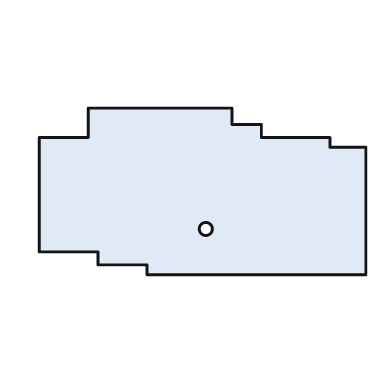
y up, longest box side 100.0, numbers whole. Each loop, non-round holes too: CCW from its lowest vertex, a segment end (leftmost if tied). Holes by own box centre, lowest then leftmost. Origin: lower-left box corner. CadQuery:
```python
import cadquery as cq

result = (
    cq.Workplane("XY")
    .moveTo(33.0, 0.0)
    .lineTo(100.0, 0.0)
    .lineTo(100.0, 39.0)
    .lineTo(89.0, 39.0)
    .lineTo(89.0, 42.0)
    .lineTo(68.0, 42.0)
    .lineTo(68.0, 46.0)
    .lineTo(59.0, 46.0)
    .lineTo(59.0, 51.0)
    .lineTo(15.0, 51.0)
    .lineTo(15.0, 42.0)
    .lineTo(0.0, 42.0)
    .lineTo(0.0, 7.0)
    .lineTo(18.0, 7.0)
    .lineTo(18.0, 3.0)
    .lineTo(33.0, 3.0)
    .close()
    .moveTo(51.0, 14.0)
    .circle(2.0)
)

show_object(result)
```